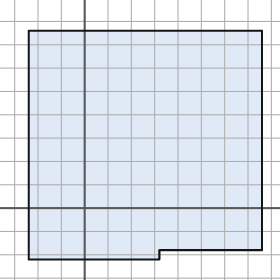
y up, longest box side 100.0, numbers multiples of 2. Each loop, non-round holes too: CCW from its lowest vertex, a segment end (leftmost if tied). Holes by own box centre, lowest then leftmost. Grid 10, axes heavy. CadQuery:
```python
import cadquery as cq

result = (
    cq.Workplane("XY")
    .moveTo(-24.0, -22.0)
    .lineTo(32.0, -22.0)
    .lineTo(32.0, -18.0)
    .lineTo(76.0, -18.0)
    .lineTo(76.0, 76.0)
    .lineTo(-24.0, 76.0)
    .close()
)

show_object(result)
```